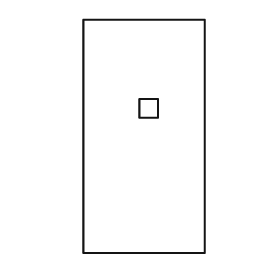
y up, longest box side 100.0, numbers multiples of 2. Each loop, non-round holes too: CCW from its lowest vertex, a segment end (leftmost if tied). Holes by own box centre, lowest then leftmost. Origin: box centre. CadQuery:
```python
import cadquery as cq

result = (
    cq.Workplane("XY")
    .moveTo(-26.0, -50.0)
    .lineTo(26.0, -50.0)
    .lineTo(26.0, 50.0)
    .lineTo(-26.0, 50.0)
    .close()
    .moveTo(-2.0, 8.0)
    .lineTo(6.0, 8.0)
    .lineTo(6.0, 16.0)
    .lineTo(-2.0, 16.0)
    .close()
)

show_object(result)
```